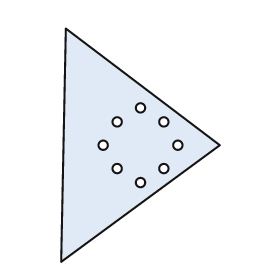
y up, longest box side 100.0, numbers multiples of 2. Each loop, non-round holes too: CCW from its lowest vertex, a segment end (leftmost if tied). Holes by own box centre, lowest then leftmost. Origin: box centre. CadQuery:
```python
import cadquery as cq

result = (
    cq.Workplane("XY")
    .moveTo(-34.0, -50.0)
    .lineTo(34.0, 0.0)
    .lineTo(-32.0, 50.0)
    .close()
    .moveTo(0.0, -16.0)
    .circle(2.0)
    .moveTo(-10.0, -10.0)
    .circle(2.0)
    .moveTo(10.0, -10.0)
    .circle(2.0)
    .moveTo(-16.0, 0.0)
    .circle(2.0)
    .moveTo(16.0, 0.0)
    .circle(2.0)
    .moveTo(-10.0, 10.0)
    .circle(2.0)
    .moveTo(10.0, 10.0)
    .circle(2.0)
    .moveTo(0.0, 16.0)
    .circle(2.0)
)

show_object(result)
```